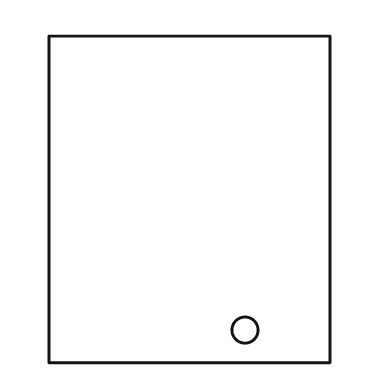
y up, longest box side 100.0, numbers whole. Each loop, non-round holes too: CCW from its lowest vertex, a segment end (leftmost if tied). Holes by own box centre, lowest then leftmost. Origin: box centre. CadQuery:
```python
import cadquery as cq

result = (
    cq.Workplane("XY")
    .moveTo(-43.0, -50.0)
    .lineTo(43.0, -50.0)
    .lineTo(43.0, 50.0)
    .lineTo(-43.0, 50.0)
    .close()
    .moveTo(17.0, -40.0)
    .circle(4.0)
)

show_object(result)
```